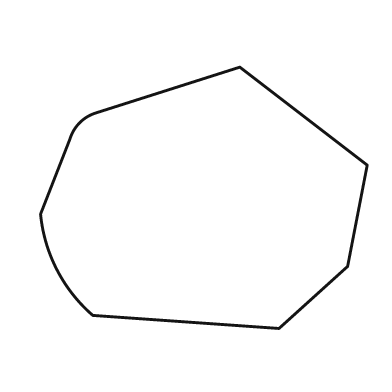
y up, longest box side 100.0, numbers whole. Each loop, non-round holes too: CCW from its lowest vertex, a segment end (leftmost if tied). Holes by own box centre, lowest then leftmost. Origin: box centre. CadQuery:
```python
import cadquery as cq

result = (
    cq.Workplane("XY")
    .moveTo(23.0, -40.0)
    .lineTo(44.0, -21.0)
    .lineTo(50.0, 10.0)
    .lineTo(11.0, 40.0)
    .lineTo(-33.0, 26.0)
    .threePointArc((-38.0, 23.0), (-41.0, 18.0))
    .lineTo(-50.0, -5.0)
    .threePointArc((-45.0, -22.0), (-34.0, -36.0))
    .close()
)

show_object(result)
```